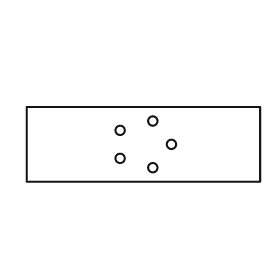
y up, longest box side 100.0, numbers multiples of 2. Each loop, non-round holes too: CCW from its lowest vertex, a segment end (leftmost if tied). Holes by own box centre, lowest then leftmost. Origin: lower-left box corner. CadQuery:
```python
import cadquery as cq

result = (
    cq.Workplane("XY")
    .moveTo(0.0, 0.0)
    .lineTo(100.0, 0.0)
    .lineTo(100.0, 32.0)
    .lineTo(0.0, 32.0)
    .close()
    .moveTo(54.0, 6.0)
    .circle(2.0)
    .moveTo(40.0, 10.0)
    .circle(2.0)
    .moveTo(62.0, 16.0)
    .circle(2.0)
    .moveTo(40.0, 22.0)
    .circle(2.0)
    .moveTo(54.0, 26.0)
    .circle(2.0)
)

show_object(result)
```